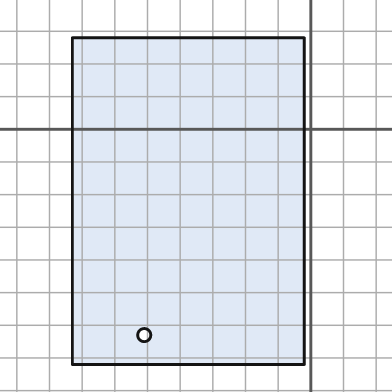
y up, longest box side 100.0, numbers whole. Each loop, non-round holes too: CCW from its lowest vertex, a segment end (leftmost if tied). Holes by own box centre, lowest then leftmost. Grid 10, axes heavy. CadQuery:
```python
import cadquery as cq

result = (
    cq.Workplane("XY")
    .moveTo(-73.0, -72.0)
    .lineTo(-2.0, -72.0)
    .lineTo(-2.0, 28.0)
    .lineTo(-73.0, 28.0)
    .close()
    .moveTo(-51.0, -63.0)
    .circle(2.0)
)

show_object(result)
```